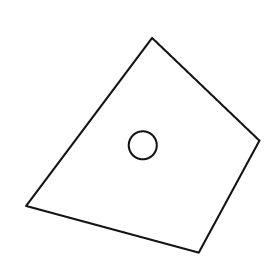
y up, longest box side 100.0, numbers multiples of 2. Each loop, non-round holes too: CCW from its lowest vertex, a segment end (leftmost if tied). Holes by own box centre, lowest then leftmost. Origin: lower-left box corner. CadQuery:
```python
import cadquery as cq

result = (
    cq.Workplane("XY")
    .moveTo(74.0, 0.0)
    .lineTo(100.0, 48.0)
    .lineTo(54.0, 92.0)
    .lineTo(0.0, 20.0)
    .close()
    .moveTo(50.0, 46.0)
    .circle(6.0)
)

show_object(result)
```